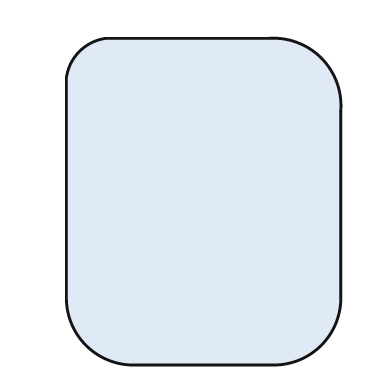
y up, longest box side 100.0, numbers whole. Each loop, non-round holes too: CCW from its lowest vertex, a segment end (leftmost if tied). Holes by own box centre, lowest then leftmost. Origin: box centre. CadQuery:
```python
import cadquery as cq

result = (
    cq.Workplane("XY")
    .moveTo(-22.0, -50.0)
    .lineTo(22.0, -50.0)
    .threePointArc((36.0, -44.0), (42.0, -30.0))
    .lineTo(42.0, 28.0)
    .threePointArc((36.0, 44.0), (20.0, 50.0))
    .lineTo(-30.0, 50.0)
    .threePointArc((-38.0, 46.0), (-42.0, 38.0))
    .lineTo(-42.0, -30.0)
    .threePointArc((-36.0, -44.0), (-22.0, -50.0))
    .close()
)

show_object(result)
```